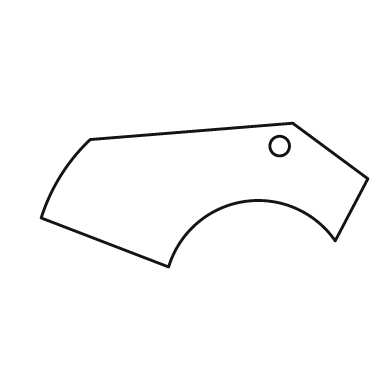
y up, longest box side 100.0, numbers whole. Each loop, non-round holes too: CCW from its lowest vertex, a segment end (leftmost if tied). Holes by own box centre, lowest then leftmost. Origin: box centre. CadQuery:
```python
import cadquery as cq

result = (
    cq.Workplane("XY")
    .moveTo(-11.0, -22.0)
    .threePointArc((12.0, -2.0), (40.0, -14.0))
    .lineTo(50.0, 5.0)
    .lineTo(27.0, 22.0)
    .lineTo(-35.0, 17.0)
    .threePointArc((-44.0, 6.0), (-50.0, -7.0))
    .close()
    .moveTo(23.0, 15.0)
    .circle(3.0)
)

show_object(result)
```